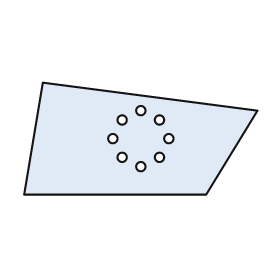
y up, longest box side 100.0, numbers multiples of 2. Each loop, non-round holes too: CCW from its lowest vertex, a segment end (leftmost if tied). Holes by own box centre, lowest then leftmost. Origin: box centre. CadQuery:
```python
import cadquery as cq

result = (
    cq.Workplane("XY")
    .moveTo(-50.0, -24.0)
    .lineTo(28.0, -24.0)
    .lineTo(50.0, 12.0)
    .lineTo(-42.0, 24.0)
    .close()
    .moveTo(0.0, -12.0)
    .circle(2.0)
    .moveTo(-8.0, -8.0)
    .circle(2.0)
    .moveTo(8.0, -8.0)
    .circle(2.0)
    .moveTo(-12.0, 0.0)
    .circle(2.0)
    .moveTo(12.0, 0.0)
    .circle(2.0)
    .moveTo(-8.0, 8.0)
    .circle(2.0)
    .moveTo(8.0, 8.0)
    .circle(2.0)
    .moveTo(0.0, 12.0)
    .circle(2.0)
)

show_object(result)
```